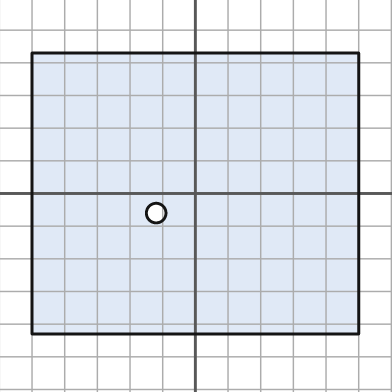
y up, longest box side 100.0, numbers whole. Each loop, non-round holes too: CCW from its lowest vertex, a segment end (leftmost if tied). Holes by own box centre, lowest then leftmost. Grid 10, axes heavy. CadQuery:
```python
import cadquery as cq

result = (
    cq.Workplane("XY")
    .moveTo(-50.0, -43.0)
    .lineTo(50.0, -43.0)
    .lineTo(50.0, 43.0)
    .lineTo(-50.0, 43.0)
    .close()
    .moveTo(-12.0, -6.0)
    .circle(3.0)
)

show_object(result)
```